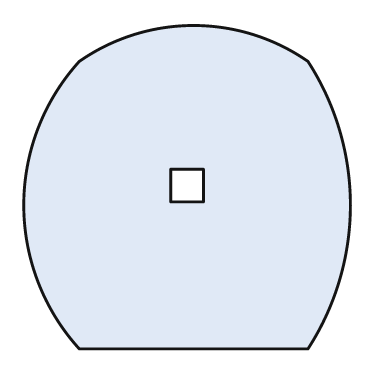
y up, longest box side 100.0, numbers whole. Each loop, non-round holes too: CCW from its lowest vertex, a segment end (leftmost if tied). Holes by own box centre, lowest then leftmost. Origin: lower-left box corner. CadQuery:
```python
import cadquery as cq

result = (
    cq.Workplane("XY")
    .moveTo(17.0, 0.0)
    .lineTo(87.0, 0.0)
    .threePointArc((100.0, 44.0), (87.0, 88.0))
    .threePointArc((52.0, 99.0), (17.0, 88.0))
    .threePointArc((0.0, 44.0), (17.0, 0.0))
    .close()
    .moveTo(45.0, 45.0)
    .lineTo(55.0, 45.0)
    .lineTo(55.0, 55.0)
    .lineTo(45.0, 55.0)
    .close()
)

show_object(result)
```